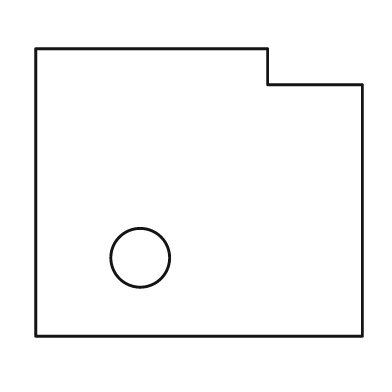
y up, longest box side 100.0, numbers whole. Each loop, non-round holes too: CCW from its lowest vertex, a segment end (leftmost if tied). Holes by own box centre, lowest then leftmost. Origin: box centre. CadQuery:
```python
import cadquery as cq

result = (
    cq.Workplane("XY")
    .moveTo(-50.0, -44.0)
    .lineTo(50.0, -44.0)
    .lineTo(50.0, 33.0)
    .lineTo(21.0, 33.0)
    .lineTo(21.0, 44.0)
    .lineTo(-50.0, 44.0)
    .close()
    .moveTo(-18.0, -20.0)
    .circle(9.0)
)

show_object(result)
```